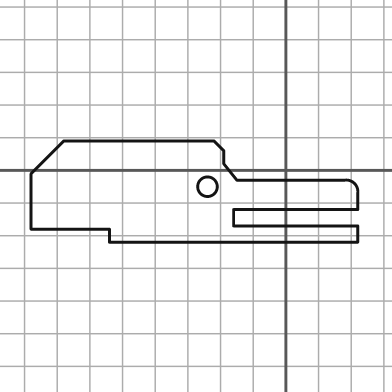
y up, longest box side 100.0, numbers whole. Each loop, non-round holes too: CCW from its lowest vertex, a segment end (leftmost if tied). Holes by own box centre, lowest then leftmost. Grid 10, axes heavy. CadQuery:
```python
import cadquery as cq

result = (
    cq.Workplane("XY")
    .moveTo(-54.0, -22.0)
    .lineTo(22.0, -22.0)
    .lineTo(22.0, -17.0)
    .lineTo(-16.0, -17.0)
    .lineTo(-16.0, -12.0)
    .lineTo(22.0, -12.0)
    .lineTo(22.0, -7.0)
    .threePointArc((21.0, -4.0), (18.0, -3.0))
    .lineTo(-15.0, -3.0)
    .lineTo(-19.0, 2.0)
    .lineTo(-19.0, 6.0)
    .lineTo(-22.0, 9.0)
    .lineTo(-68.0, 9.0)
    .lineTo(-78.0, -1.0)
    .lineTo(-78.0, -18.0)
    .lineTo(-54.0, -18.0)
    .close()
    .moveTo(-24.0, -5.0)
    .circle(3.0)
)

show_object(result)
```